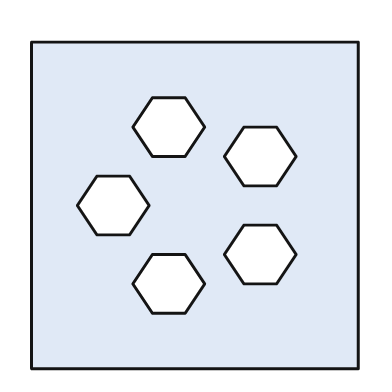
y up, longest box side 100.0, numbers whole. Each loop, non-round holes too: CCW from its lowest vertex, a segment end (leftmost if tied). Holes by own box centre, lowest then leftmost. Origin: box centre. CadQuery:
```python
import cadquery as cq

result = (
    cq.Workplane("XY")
    .moveTo(-50.0, -50.0)
    .lineTo(50.0, -50.0)
    .lineTo(50.0, 50.0)
    .lineTo(-50.0, 50.0)
    .close()
    .moveTo(-13.0, -33.0)
    .lineTo(-3.0, -33.0)
    .lineTo(3.0, -24.0)
    .lineTo(-3.0, -15.0)
    .lineTo(-13.0, -15.0)
    .lineTo(-19.0, -24.0)
    .close()
    .moveTo(15.0, -24.0)
    .lineTo(25.0, -24.0)
    .lineTo(31.0, -15.0)
    .lineTo(25.0, -6.0)
    .lineTo(15.0, -6.0)
    .lineTo(9.0, -15.0)
    .close()
    .moveTo(-30.0, -9.0)
    .lineTo(-20.0, -9.0)
    .lineTo(-14.0, 0.0)
    .lineTo(-20.0, 9.0)
    .lineTo(-30.0, 9.0)
    .lineTo(-36.0, 0.0)
    .close()
    .moveTo(15.0, 6.0)
    .lineTo(25.0, 6.0)
    .lineTo(31.0, 15.0)
    .lineTo(25.0, 24.0)
    .lineTo(15.0, 24.0)
    .lineTo(9.0, 15.0)
    .close()
    .moveTo(-13.0, 15.0)
    .lineTo(-3.0, 15.0)
    .lineTo(3.0, 24.0)
    .lineTo(-3.0, 33.0)
    .lineTo(-13.0, 33.0)
    .lineTo(-19.0, 24.0)
    .close()
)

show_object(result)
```